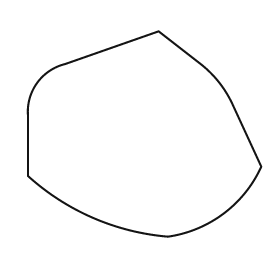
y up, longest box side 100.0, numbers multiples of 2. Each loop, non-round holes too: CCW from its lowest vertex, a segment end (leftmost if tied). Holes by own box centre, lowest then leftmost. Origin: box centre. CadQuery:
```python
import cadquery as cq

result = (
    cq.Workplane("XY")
    .moveTo(10.0, -44.0)
    .threePointArc((34.0, -34.0), (50.0, -14.0))
    .lineTo(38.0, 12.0)
    .threePointArc((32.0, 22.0), (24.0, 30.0))
    .lineTo(6.0, 44.0)
    .lineTo(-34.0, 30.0)
    .threePointArc((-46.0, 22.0), (-50.0, 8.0))
    .lineTo(-50.0, -18.0)
    .threePointArc((-22.0, -36.0), (10.0, -44.0))
    .close()
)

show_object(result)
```